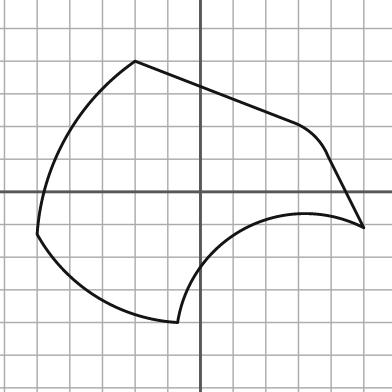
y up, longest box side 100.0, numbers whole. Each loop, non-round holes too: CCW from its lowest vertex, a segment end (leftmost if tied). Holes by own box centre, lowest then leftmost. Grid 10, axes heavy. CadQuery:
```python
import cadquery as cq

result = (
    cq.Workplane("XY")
    .moveTo(-7.0, -40.0)
    .threePointArc((14.0, -11.0), (50.0, -11.0))
    .lineTo(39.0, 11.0)
    .threePointArc((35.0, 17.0), (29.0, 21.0))
    .lineTo(-20.0, 40.0)
    .threePointArc((-41.0, 17.0), (-50.0, -13.0))
    .threePointArc((-32.0, -32.0), (-7.0, -40.0))
    .close()
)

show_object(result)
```